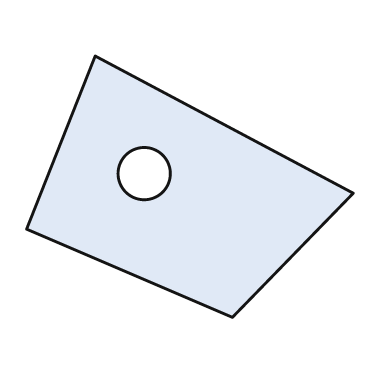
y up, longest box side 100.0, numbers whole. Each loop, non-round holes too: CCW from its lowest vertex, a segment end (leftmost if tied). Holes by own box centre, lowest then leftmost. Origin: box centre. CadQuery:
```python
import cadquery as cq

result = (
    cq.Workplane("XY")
    .moveTo(13.0, -40.0)
    .lineTo(50.0, -2.0)
    .lineTo(-29.0, 40.0)
    .lineTo(-50.0, -13.0)
    .close()
    .moveTo(-14.0, 4.0)
    .circle(8.0)
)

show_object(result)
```